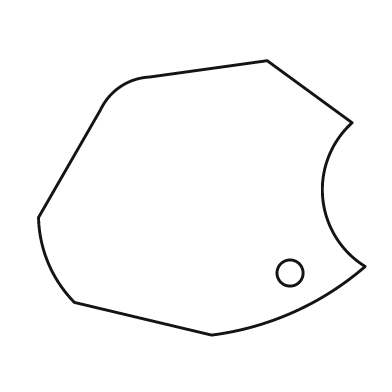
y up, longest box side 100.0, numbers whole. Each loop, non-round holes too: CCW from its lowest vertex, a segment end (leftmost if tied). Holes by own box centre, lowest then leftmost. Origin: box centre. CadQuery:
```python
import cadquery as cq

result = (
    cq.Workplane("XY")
    .moveTo(3.0, -42.0)
    .threePointArc((28.0, -35.0), (50.0, -21.0))
    .threePointArc((37.0, 0.0), (46.0, 23.0))
    .lineTo(20.0, 42.0)
    .lineTo(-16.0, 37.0)
    .threePointArc((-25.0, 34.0), (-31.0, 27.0))
    .lineTo(-50.0, -6.0)
    .threePointArc((-47.0, -20.0), (-39.0, -32.0))
    .close()
    .moveTo(27.0, -23.0)
    .circle(4.0)
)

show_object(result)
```